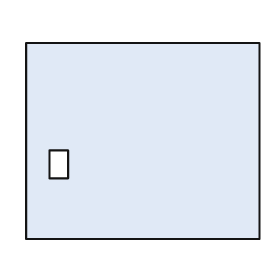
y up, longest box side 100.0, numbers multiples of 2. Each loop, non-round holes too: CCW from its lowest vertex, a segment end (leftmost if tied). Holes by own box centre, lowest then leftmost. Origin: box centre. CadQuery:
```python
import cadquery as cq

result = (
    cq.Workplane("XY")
    .moveTo(-50.0, -42.0)
    .lineTo(50.0, -42.0)
    .lineTo(50.0, 42.0)
    .lineTo(-50.0, 42.0)
    .close()
    .moveTo(-40.0, -16.0)
    .lineTo(-32.0, -16.0)
    .lineTo(-32.0, -4.0)
    .lineTo(-40.0, -4.0)
    .close()
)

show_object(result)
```